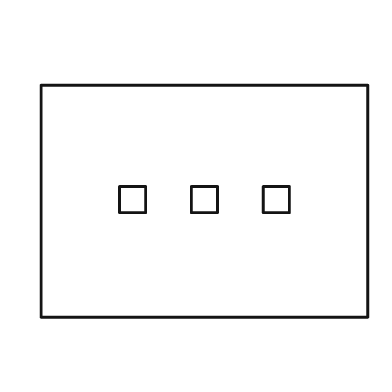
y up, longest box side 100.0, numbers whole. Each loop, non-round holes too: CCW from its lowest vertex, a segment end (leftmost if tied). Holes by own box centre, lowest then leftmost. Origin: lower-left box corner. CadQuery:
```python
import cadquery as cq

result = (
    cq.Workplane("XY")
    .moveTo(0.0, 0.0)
    .lineTo(100.0, 0.0)
    .lineTo(100.0, 71.0)
    .lineTo(0.0, 71.0)
    .close()
    .moveTo(24.0, 32.0)
    .lineTo(32.0, 32.0)
    .lineTo(32.0, 40.0)
    .lineTo(24.0, 40.0)
    .close()
    .moveTo(46.0, 32.0)
    .lineTo(54.0, 32.0)
    .lineTo(54.0, 40.0)
    .lineTo(46.0, 40.0)
    .close()
    .moveTo(68.0, 32.0)
    .lineTo(76.0, 32.0)
    .lineTo(76.0, 40.0)
    .lineTo(68.0, 40.0)
    .close()
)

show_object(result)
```